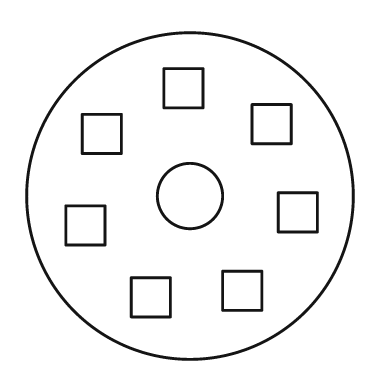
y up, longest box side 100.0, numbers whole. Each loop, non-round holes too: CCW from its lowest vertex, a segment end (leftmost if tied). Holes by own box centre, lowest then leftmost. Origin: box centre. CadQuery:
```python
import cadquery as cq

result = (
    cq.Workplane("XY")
    .moveTo(0.0, 0.0)
    .circle(50.0)
    .moveTo(-18.0, -37.0)
    .lineTo(-6.0, -37.0)
    .lineTo(-6.0, -25.0)
    .lineTo(-18.0, -25.0)
    .close()
    .moveTo(10.0, -35.0)
    .lineTo(22.0, -35.0)
    .lineTo(22.0, -23.0)
    .lineTo(10.0, -23.0)
    .close()
    .moveTo(-38.0, -15.0)
    .lineTo(-26.0, -15.0)
    .lineTo(-26.0, -3.0)
    .lineTo(-38.0, -3.0)
    .close()
    .moveTo(27.0, -11.0)
    .lineTo(39.0, -11.0)
    .lineTo(39.0, 1.0)
    .lineTo(27.0, 1.0)
    .close()
    .moveTo(0.0, 0.0)
    .circle(10.0)
    .moveTo(-33.0, 13.0)
    .lineTo(-21.0, 13.0)
    .lineTo(-21.0, 25.0)
    .lineTo(-33.0, 25.0)
    .close()
    .moveTo(19.0, 16.0)
    .lineTo(31.0, 16.0)
    .lineTo(31.0, 28.0)
    .lineTo(19.0, 28.0)
    .close()
    .moveTo(-8.0, 27.0)
    .lineTo(4.0, 27.0)
    .lineTo(4.0, 39.0)
    .lineTo(-8.0, 39.0)
    .close()
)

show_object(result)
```